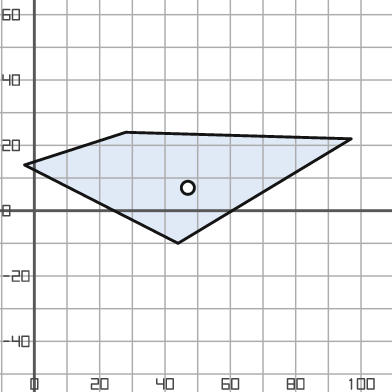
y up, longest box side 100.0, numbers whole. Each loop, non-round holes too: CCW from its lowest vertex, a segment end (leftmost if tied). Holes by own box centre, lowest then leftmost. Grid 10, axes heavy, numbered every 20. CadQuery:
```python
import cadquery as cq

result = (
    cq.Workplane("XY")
    .moveTo(44.0, -10.0)
    .lineTo(97.0, 22.0)
    .lineTo(28.0, 24.0)
    .lineTo(-3.0, 14.0)
    .close()
    .moveTo(47.0, 7.0)
    .circle(2.0)
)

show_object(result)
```